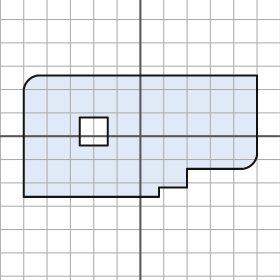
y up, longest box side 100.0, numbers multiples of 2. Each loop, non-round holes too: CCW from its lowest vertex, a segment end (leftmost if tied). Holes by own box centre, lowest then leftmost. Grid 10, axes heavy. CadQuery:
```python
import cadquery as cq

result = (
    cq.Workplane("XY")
    .moveTo(-50.0, -26.0)
    .lineTo(8.0, -26.0)
    .lineTo(8.0, -22.0)
    .lineTo(20.0, -22.0)
    .lineTo(20.0, -14.0)
    .lineTo(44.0, -14.0)
    .threePointArc((48.0, -12.0), (50.0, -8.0))
    .lineTo(50.0, 26.0)
    .lineTo(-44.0, 26.0)
    .threePointArc((-48.0, 24.0), (-50.0, 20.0))
    .close()
    .moveTo(-26.0, -4.0)
    .lineTo(-14.0, -4.0)
    .lineTo(-14.0, 8.0)
    .lineTo(-26.0, 8.0)
    .close()
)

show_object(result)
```